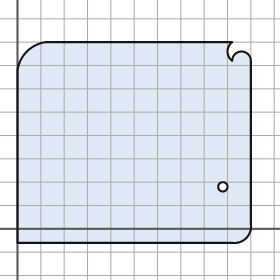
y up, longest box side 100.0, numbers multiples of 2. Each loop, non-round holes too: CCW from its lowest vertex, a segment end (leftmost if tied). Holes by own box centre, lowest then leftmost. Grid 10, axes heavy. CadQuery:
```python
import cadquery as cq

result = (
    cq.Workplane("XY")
    .moveTo(0.0, -6.0)
    .lineTo(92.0, -6.0)
    .threePointArc((98.0, -4.0), (100.0, 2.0))
    .lineTo(100.0, 72.0)
    .threePointArc((96.0, 76.0), (92.0, 72.0))
    .threePointArc((90.0, 76.0), (92.0, 80.0))
    .lineTo(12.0, 80.0)
    .threePointArc((4.0, 76.0), (0.0, 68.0))
    .close()
    .moveTo(88.0, 18.0)
    .circle(2.0)
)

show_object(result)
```